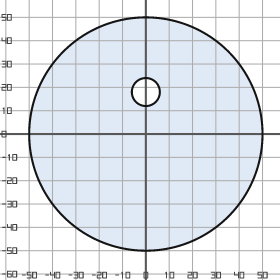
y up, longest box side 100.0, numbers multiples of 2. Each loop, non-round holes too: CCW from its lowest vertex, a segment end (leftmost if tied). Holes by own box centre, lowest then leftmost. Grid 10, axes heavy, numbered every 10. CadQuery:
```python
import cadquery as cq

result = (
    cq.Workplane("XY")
    .moveTo(0.0, 0.0)
    .circle(50.0)
    .moveTo(0.0, 18.0)
    .circle(6.0)
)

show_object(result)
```